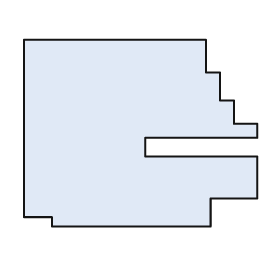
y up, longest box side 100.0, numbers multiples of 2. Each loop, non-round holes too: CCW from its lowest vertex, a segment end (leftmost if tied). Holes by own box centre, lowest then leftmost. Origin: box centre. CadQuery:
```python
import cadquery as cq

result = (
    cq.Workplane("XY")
    .moveTo(-38.0, -40.0)
    .lineTo(30.0, -40.0)
    .lineTo(30.0, -28.0)
    .lineTo(50.0, -28.0)
    .lineTo(50.0, -10.0)
    .lineTo(2.0, -10.0)
    .lineTo(2.0, -2.0)
    .lineTo(50.0, -2.0)
    .lineTo(50.0, 4.0)
    .lineTo(40.0, 4.0)
    .lineTo(40.0, 14.0)
    .lineTo(34.0, 14.0)
    .lineTo(34.0, 26.0)
    .lineTo(28.0, 26.0)
    .lineTo(28.0, 40.0)
    .lineTo(-50.0, 40.0)
    .lineTo(-50.0, -36.0)
    .lineTo(-38.0, -36.0)
    .close()
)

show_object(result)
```